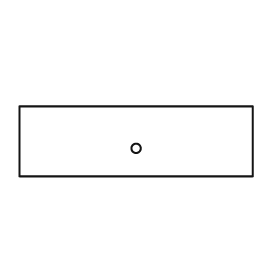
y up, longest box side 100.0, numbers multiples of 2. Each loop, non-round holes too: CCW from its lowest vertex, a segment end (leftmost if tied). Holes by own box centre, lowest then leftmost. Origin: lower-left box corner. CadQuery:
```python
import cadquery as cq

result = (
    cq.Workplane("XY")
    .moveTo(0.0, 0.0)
    .lineTo(100.0, 0.0)
    .lineTo(100.0, 30.0)
    .lineTo(0.0, 30.0)
    .close()
    .moveTo(50.0, 12.0)
    .circle(2.0)
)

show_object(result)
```